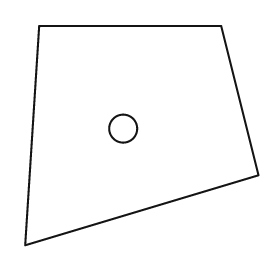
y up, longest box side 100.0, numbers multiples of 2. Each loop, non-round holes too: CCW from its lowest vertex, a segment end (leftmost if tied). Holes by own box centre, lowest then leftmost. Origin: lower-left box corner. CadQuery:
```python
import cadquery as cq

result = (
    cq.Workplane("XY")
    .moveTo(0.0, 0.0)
    .lineTo(100.0, 30.0)
    .lineTo(84.0, 94.0)
    .lineTo(6.0, 94.0)
    .close()
    .moveTo(42.0, 50.0)
    .circle(6.0)
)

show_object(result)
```